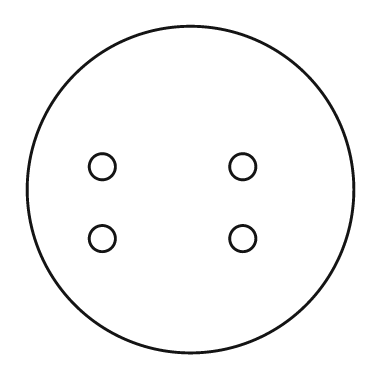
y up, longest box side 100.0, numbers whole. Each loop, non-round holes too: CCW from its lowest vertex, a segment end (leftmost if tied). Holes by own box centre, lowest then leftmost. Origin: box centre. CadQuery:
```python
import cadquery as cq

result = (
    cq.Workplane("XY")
    .moveTo(0.0, 0.0)
    .circle(50.0)
    .moveTo(-27.0, -15.0)
    .circle(4.0)
    .moveTo(16.0, -15.0)
    .circle(4.0)
    .moveTo(-27.0, 7.0)
    .circle(4.0)
    .moveTo(16.0, 7.0)
    .circle(4.0)
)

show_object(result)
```